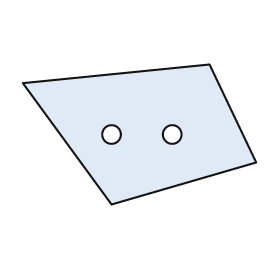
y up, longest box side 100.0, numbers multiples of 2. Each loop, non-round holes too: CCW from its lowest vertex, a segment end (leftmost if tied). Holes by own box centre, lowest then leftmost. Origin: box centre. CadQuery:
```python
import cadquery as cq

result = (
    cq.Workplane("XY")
    .moveTo(-12.0, -30.0)
    .lineTo(50.0, -12.0)
    .lineTo(30.0, 30.0)
    .lineTo(-50.0, 22.0)
    .close()
    .moveTo(-12.0, 0.0)
    .circle(4.0)
    .moveTo(14.0, 0.0)
    .circle(4.0)
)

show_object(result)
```